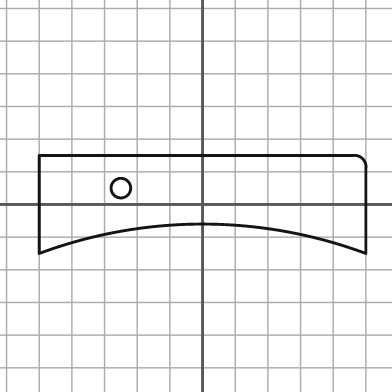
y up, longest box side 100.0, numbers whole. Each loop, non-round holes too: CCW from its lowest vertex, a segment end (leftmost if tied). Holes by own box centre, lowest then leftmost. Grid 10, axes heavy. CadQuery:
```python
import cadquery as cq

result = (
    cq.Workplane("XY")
    .moveTo(-50.0, -15.0)
    .threePointArc((0.0, -6.0), (50.0, -15.0))
    .lineTo(50.0, 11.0)
    .threePointArc((49.0, 14.0), (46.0, 15.0))
    .lineTo(-50.0, 15.0)
    .close()
    .moveTo(-25.0, 5.0)
    .circle(3.0)
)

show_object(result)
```